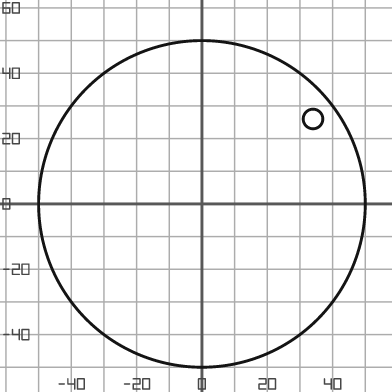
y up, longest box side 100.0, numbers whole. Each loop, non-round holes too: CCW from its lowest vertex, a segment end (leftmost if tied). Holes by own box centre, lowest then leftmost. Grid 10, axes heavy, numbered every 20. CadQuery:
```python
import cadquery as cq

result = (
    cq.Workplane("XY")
    .moveTo(0.0, 0.0)
    .circle(50.0)
    .moveTo(34.0, 26.0)
    .circle(3.0)
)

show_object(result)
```